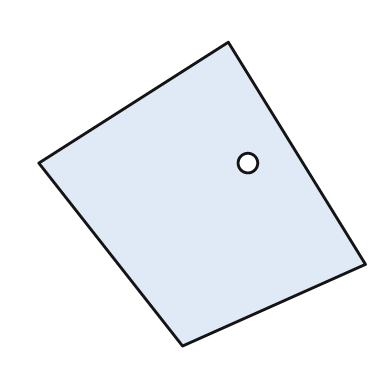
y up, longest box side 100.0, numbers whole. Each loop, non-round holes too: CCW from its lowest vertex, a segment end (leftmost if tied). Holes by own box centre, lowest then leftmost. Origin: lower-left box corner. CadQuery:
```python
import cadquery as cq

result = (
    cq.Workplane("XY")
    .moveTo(44.0, 0.0)
    .lineTo(100.0, 25.0)
    .lineTo(58.0, 93.0)
    .lineTo(0.0, 56.0)
    .close()
    .moveTo(64.0, 56.0)
    .circle(3.0)
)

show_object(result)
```